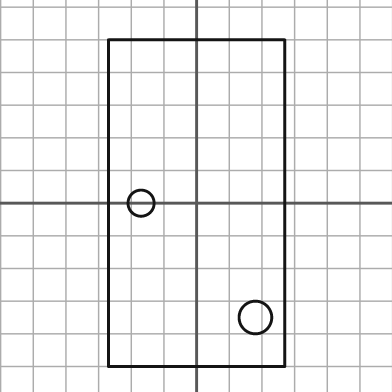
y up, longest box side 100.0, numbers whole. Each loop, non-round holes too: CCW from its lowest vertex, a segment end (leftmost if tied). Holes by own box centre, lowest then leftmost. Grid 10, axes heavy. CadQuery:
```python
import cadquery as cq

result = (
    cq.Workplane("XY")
    .moveTo(-27.0, -50.0)
    .lineTo(27.0, -50.0)
    .lineTo(27.0, 50.0)
    .lineTo(-27.0, 50.0)
    .close()
    .moveTo(18.0, -35.0)
    .circle(5.0)
    .moveTo(-17.0, 0.0)
    .circle(4.0)
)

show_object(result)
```